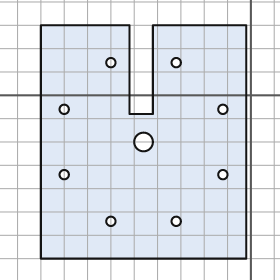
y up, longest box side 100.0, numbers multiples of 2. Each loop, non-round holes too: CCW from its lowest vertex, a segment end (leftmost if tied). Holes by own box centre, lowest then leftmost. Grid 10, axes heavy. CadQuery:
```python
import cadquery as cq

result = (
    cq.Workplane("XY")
    .moveTo(-90.0, -70.0)
    .lineTo(-2.0, -70.0)
    .lineTo(-2.0, 30.0)
    .lineTo(-42.0, 30.0)
    .lineTo(-42.0, -8.0)
    .lineTo(-52.0, -8.0)
    .lineTo(-52.0, 30.0)
    .lineTo(-90.0, 30.0)
    .close()
    .moveTo(-60.0, -54.0)
    .circle(2.0)
    .moveTo(-32.0, -54.0)
    .circle(2.0)
    .moveTo(-80.0, -34.0)
    .circle(2.0)
    .moveTo(-12.0, -34.0)
    .circle(2.0)
    .moveTo(-46.0, -20.0)
    .circle(4.0)
    .moveTo(-80.0, -6.0)
    .circle(2.0)
    .moveTo(-12.0, -6.0)
    .circle(2.0)
    .moveTo(-60.0, 14.0)
    .circle(2.0)
    .moveTo(-32.0, 14.0)
    .circle(2.0)
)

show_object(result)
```